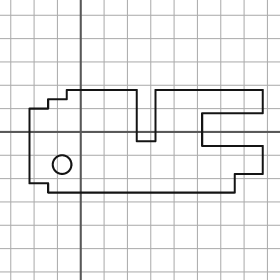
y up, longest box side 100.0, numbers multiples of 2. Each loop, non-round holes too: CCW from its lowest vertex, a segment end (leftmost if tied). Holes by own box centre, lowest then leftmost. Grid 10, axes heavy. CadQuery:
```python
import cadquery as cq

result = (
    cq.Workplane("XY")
    .moveTo(-14.0, -26.0)
    .lineTo(66.0, -26.0)
    .lineTo(66.0, -18.0)
    .lineTo(78.0, -18.0)
    .lineTo(78.0, -6.0)
    .lineTo(52.0, -6.0)
    .lineTo(52.0, 8.0)
    .lineTo(78.0, 8.0)
    .lineTo(78.0, 18.0)
    .lineTo(32.0, 18.0)
    .lineTo(32.0, -4.0)
    .lineTo(24.0, -4.0)
    .lineTo(24.0, 18.0)
    .lineTo(-6.0, 18.0)
    .lineTo(-6.0, 14.0)
    .lineTo(-14.0, 14.0)
    .lineTo(-14.0, 10.0)
    .lineTo(-22.0, 10.0)
    .lineTo(-22.0, -22.0)
    .lineTo(-14.0, -22.0)
    .close()
    .moveTo(-8.0, -14.0)
    .circle(4.0)
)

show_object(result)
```